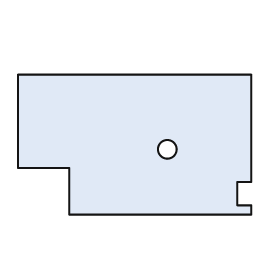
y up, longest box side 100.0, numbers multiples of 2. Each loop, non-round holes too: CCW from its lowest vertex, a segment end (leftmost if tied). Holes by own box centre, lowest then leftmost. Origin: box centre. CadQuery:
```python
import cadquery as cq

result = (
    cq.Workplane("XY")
    .moveTo(-28.0, -30.0)
    .lineTo(50.0, -30.0)
    .lineTo(50.0, -26.0)
    .lineTo(44.0, -26.0)
    .lineTo(44.0, -16.0)
    .lineTo(50.0, -16.0)
    .lineTo(50.0, 30.0)
    .lineTo(-50.0, 30.0)
    .lineTo(-50.0, -10.0)
    .lineTo(-28.0, -10.0)
    .close()
    .moveTo(14.0, -2.0)
    .circle(4.0)
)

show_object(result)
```